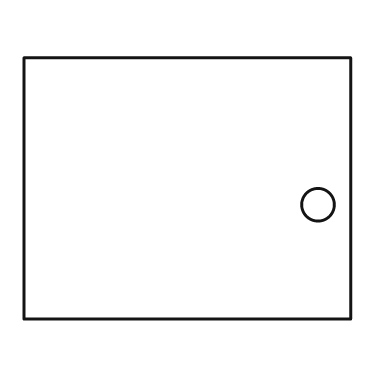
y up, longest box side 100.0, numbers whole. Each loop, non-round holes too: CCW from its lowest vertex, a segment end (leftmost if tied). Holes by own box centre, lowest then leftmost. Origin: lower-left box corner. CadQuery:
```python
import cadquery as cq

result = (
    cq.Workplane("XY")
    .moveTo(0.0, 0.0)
    .lineTo(100.0, 0.0)
    .lineTo(100.0, 80.0)
    .lineTo(0.0, 80.0)
    .close()
    .moveTo(90.0, 35.0)
    .circle(5.0)
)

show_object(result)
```